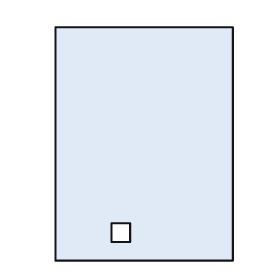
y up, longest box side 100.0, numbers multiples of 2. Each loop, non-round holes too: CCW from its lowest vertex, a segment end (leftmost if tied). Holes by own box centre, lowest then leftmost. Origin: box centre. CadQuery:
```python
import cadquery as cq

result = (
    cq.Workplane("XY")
    .moveTo(-38.0, -50.0)
    .lineTo(38.0, -50.0)
    .lineTo(38.0, 50.0)
    .lineTo(-38.0, 50.0)
    .close()
    .moveTo(-14.0, -42.0)
    .lineTo(-6.0, -42.0)
    .lineTo(-6.0, -34.0)
    .lineTo(-14.0, -34.0)
    .close()
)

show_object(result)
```